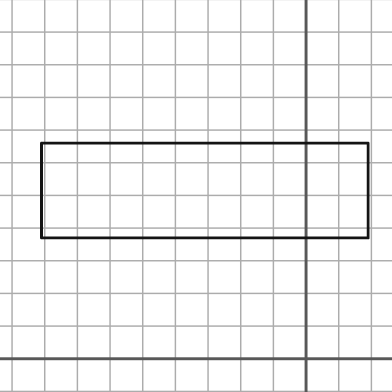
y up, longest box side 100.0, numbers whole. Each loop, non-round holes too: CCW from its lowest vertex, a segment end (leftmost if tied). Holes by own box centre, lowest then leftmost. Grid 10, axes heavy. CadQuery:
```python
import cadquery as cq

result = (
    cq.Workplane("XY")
    .moveTo(-81.0, 37.0)
    .lineTo(19.0, 37.0)
    .lineTo(19.0, 66.0)
    .lineTo(-81.0, 66.0)
    .close()
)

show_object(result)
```